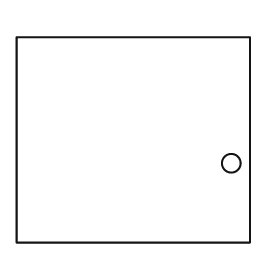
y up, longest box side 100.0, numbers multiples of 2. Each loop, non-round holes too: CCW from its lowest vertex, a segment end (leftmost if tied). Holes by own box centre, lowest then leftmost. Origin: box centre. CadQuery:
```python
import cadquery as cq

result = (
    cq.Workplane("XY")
    .moveTo(-50.0, -44.0)
    .lineTo(50.0, -44.0)
    .lineTo(50.0, 44.0)
    .lineTo(-50.0, 44.0)
    .close()
    .moveTo(42.0, -10.0)
    .circle(4.0)
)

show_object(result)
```